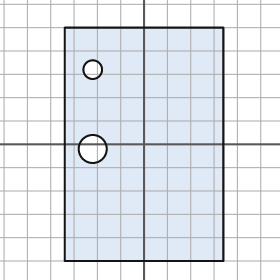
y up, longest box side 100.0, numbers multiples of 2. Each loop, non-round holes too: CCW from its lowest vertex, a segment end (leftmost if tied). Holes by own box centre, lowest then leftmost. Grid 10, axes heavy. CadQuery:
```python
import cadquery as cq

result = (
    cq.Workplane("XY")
    .moveTo(-34.0, -50.0)
    .lineTo(34.0, -50.0)
    .lineTo(34.0, 50.0)
    .lineTo(-34.0, 50.0)
    .close()
    .moveTo(-22.0, -2.0)
    .circle(6.0)
    .moveTo(-22.0, 32.0)
    .circle(4.0)
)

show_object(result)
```